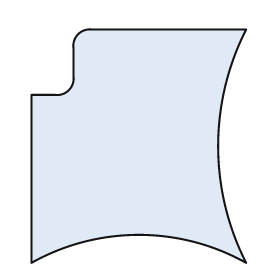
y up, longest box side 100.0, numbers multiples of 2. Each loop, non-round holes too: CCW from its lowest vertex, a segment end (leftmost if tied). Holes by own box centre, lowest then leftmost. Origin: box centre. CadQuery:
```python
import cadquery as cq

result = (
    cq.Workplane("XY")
    .moveTo(-46.0, -50.0)
    .threePointArc((0.0, -38.0), (46.0, -50.0))
    .threePointArc((34.0, 0.0), (46.0, 50.0))
    .lineTo(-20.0, 50.0)
    .threePointArc((-26.0, 48.0), (-28.0, 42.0))
    .lineTo(-28.0, 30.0)
    .threePointArc((-30.0, 24.0), (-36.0, 22.0))
    .lineTo(-46.0, 22.0)
    .close()
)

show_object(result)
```